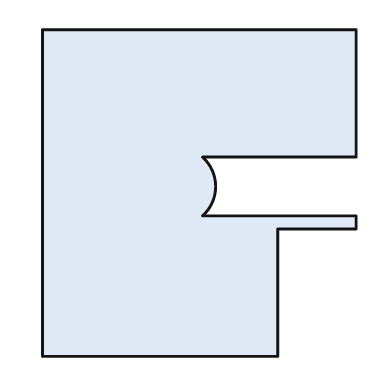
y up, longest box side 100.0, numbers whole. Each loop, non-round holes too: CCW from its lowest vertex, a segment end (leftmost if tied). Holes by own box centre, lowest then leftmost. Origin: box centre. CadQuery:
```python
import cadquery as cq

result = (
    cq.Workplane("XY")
    .moveTo(-48.0, -50.0)
    .lineTo(24.0, -50.0)
    .lineTo(24.0, -11.0)
    .lineTo(48.0, -11.0)
    .lineTo(48.0, -7.0)
    .lineTo(1.0, -7.0)
    .threePointArc((5.0, 2.0), (1.0, 11.0))
    .lineTo(48.0, 11.0)
    .lineTo(48.0, 50.0)
    .lineTo(-48.0, 50.0)
    .close()
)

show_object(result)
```